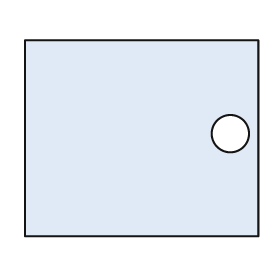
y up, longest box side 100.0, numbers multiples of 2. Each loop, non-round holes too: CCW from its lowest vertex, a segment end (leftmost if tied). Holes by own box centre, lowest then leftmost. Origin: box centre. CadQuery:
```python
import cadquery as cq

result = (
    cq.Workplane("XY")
    .moveTo(-50.0, -42.0)
    .lineTo(50.0, -42.0)
    .lineTo(50.0, 42.0)
    .lineTo(-50.0, 42.0)
    .close()
    .moveTo(38.0, 2.0)
    .circle(8.0)
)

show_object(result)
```